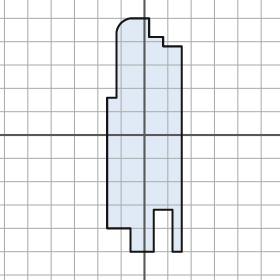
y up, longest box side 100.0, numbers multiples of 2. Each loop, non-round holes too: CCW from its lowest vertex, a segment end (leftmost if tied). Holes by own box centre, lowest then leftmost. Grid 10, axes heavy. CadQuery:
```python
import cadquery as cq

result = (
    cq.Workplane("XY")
    .moveTo(-6.0, -50.0)
    .lineTo(4.0, -50.0)
    .lineTo(4.0, -32.0)
    .lineTo(12.0, -32.0)
    .lineTo(12.0, -50.0)
    .lineTo(16.0, -50.0)
    .lineTo(16.0, 38.0)
    .lineTo(8.0, 38.0)
    .lineTo(8.0, 42.0)
    .lineTo(2.0, 42.0)
    .lineTo(2.0, 50.0)
    .lineTo(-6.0, 50.0)
    .threePointArc((-10.0, 48.0), (-12.0, 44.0))
    .lineTo(-12.0, 16.0)
    .lineTo(-16.0, 16.0)
    .lineTo(-16.0, -40.0)
    .lineTo(-6.0, -40.0)
    .close()
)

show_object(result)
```